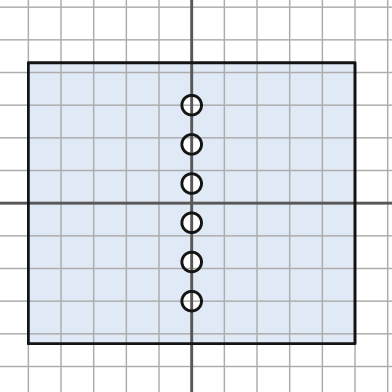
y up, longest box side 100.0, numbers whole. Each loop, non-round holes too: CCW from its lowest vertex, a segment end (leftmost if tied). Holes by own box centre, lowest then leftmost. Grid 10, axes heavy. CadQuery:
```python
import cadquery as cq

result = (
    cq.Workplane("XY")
    .moveTo(-50.0, -43.0)
    .lineTo(50.0, -43.0)
    .lineTo(50.0, 43.0)
    .lineTo(-50.0, 43.0)
    .close()
    .moveTo(0.0, -30.0)
    .circle(3.0)
    .moveTo(0.0, -18.0)
    .circle(3.0)
    .moveTo(0.0, -6.0)
    .circle(3.0)
    .moveTo(0.0, 6.0)
    .circle(3.0)
    .moveTo(0.0, 18.0)
    .circle(3.0)
    .moveTo(0.0, 30.0)
    .circle(3.0)
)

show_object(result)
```